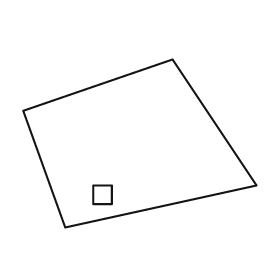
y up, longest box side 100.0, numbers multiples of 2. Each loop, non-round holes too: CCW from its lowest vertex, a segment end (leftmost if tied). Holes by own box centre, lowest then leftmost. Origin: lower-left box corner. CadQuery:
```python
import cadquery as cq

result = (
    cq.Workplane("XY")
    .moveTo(18.0, 0.0)
    .lineTo(100.0, 18.0)
    .lineTo(64.0, 72.0)
    .lineTo(0.0, 50.0)
    .close()
    .moveTo(30.0, 10.0)
    .lineTo(38.0, 10.0)
    .lineTo(38.0, 18.0)
    .lineTo(30.0, 18.0)
    .close()
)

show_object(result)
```